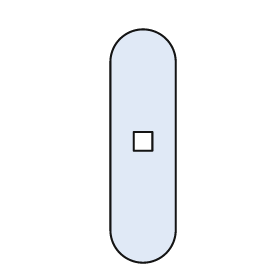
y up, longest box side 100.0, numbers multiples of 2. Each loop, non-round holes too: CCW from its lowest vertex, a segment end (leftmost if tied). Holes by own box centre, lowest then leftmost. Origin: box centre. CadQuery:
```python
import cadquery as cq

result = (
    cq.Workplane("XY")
    .moveTo(-14.0, -36.0)
    .threePointArc((0.0, -50.0), (14.0, -36.0))
    .lineTo(14.0, 36.0)
    .threePointArc((0.0, 50.0), (-14.0, 36.0))
    .close()
    .moveTo(-4.0, -2.0)
    .lineTo(4.0, -2.0)
    .lineTo(4.0, 6.0)
    .lineTo(-4.0, 6.0)
    .close()
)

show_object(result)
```